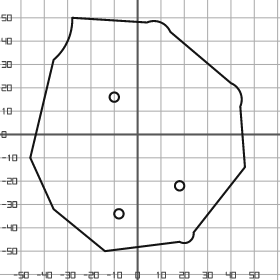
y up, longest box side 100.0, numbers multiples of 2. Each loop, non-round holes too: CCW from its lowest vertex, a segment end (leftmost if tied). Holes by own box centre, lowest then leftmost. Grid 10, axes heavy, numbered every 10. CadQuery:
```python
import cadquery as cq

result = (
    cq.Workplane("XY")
    .moveTo(-14.0, -50.0)
    .lineTo(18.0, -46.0)
    .threePointArc((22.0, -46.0), (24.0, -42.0))
    .lineTo(46.0, -14.0)
    .lineTo(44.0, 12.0)
    .threePointArc((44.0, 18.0), (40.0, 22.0))
    .lineTo(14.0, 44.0)
    .threePointArc((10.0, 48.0), (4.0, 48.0))
    .lineTo(-28.0, 50.0)
    .threePointArc((-30.0, 40.0), (-36.0, 32.0))
    .lineTo(-46.0, -10.0)
    .lineTo(-36.0, -32.0)
    .close()
    .moveTo(-8.0, -34.0)
    .circle(2.0)
    .moveTo(18.0, -22.0)
    .circle(2.0)
    .moveTo(-10.0, 16.0)
    .circle(2.0)
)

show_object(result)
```